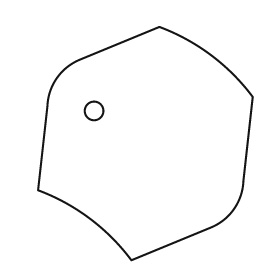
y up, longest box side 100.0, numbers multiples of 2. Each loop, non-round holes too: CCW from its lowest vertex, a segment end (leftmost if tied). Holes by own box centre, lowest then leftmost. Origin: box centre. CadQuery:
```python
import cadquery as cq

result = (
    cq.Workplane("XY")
    .moveTo(-6.0, -50.0)
    .lineTo(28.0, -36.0)
    .threePointArc((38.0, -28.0), (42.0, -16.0))
    .lineTo(46.0, 20.0)
    .threePointArc((28.0, 38.0), (6.0, 50.0))
    .lineTo(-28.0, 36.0)
    .threePointArc((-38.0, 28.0), (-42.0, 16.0))
    .lineTo(-46.0, -20.0)
    .threePointArc((-24.0, -32.0), (-6.0, -50.0))
    .close()
    .moveTo(-22.0, 14.0)
    .circle(4.0)
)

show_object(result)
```